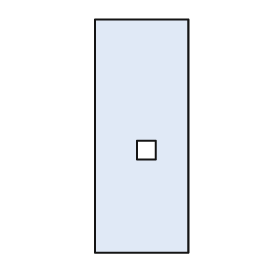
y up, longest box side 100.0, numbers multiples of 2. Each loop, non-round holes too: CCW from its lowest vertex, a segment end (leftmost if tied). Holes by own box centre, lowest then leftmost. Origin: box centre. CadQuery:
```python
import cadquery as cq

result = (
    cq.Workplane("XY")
    .moveTo(-20.0, -50.0)
    .lineTo(20.0, -50.0)
    .lineTo(20.0, 50.0)
    .lineTo(-20.0, 50.0)
    .close()
    .moveTo(-2.0, -10.0)
    .lineTo(6.0, -10.0)
    .lineTo(6.0, -2.0)
    .lineTo(-2.0, -2.0)
    .close()
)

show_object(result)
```